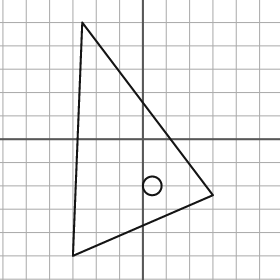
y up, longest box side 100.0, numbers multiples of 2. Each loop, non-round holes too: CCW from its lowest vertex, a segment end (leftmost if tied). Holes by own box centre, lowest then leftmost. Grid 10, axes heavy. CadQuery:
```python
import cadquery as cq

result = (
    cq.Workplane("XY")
    .moveTo(-30.0, -50.0)
    .lineTo(30.0, -24.0)
    .lineTo(-26.0, 50.0)
    .close()
    .moveTo(4.0, -20.0)
    .circle(4.0)
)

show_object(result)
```